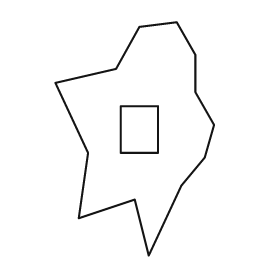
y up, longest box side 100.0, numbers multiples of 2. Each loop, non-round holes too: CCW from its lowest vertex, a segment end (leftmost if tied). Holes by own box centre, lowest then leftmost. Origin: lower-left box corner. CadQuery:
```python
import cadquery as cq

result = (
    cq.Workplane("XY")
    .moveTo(40.0, 0.0)
    .lineTo(54.0, 30.0)
    .lineTo(64.0, 42.0)
    .lineTo(68.0, 56.0)
    .lineTo(60.0, 70.0)
    .lineTo(60.0, 86.0)
    .lineTo(52.0, 100.0)
    .lineTo(36.0, 98.0)
    .lineTo(26.0, 80.0)
    .lineTo(0.0, 74.0)
    .lineTo(14.0, 44.0)
    .lineTo(10.0, 16.0)
    .lineTo(34.0, 24.0)
    .close()
    .moveTo(28.0, 44.0)
    .lineTo(44.0, 44.0)
    .lineTo(44.0, 64.0)
    .lineTo(28.0, 64.0)
    .close()
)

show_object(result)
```